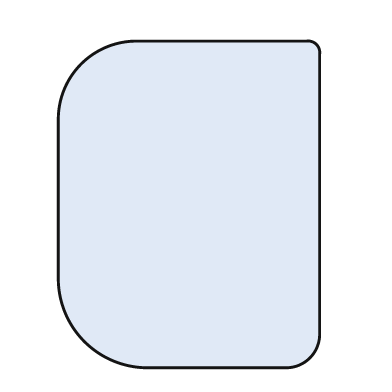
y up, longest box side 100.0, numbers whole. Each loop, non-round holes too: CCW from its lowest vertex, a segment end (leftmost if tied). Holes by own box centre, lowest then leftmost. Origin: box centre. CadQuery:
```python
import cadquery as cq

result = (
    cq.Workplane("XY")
    .moveTo(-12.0, -50.0)
    .lineTo(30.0, -50.0)
    .threePointArc((37.0, -47.0), (40.0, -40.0))
    .lineTo(40.0, 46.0)
    .threePointArc((39.0, 49.0), (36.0, 50.0))
    .lineTo(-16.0, 50.0)
    .threePointArc((-33.0, 43.0), (-40.0, 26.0))
    .lineTo(-40.0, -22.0)
    .threePointArc((-32.0, -42.0), (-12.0, -50.0))
    .close()
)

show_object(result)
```